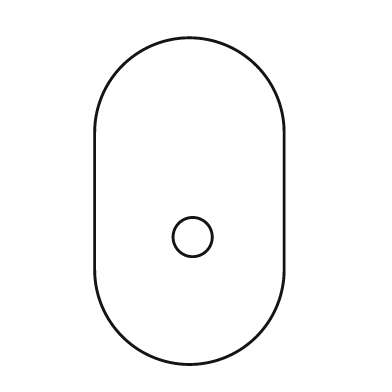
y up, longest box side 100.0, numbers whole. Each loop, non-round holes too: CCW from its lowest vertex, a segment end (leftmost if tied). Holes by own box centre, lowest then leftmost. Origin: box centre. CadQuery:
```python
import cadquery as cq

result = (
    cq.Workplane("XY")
    .moveTo(-29.0, -21.0)
    .threePointArc((0.0, -50.0), (29.0, -21.0))
    .lineTo(29.0, 21.0)
    .threePointArc((0.0, 50.0), (-29.0, 21.0))
    .close()
    .moveTo(1.0, -11.0)
    .circle(6.0)
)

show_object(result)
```